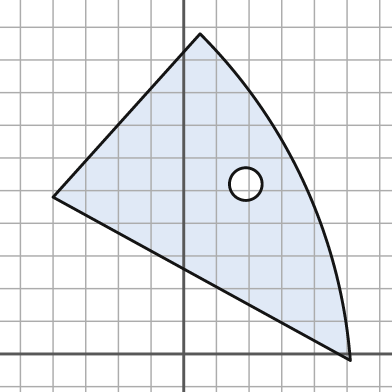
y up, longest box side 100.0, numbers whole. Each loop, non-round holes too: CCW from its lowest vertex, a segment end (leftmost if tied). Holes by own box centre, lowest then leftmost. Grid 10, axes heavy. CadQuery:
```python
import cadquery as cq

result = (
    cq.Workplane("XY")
    .moveTo(51.0, -2.0)
    .threePointArc((37.0, 52.0), (5.0, 98.0))
    .lineTo(-40.0, 48.0)
    .close()
    .moveTo(19.0, 52.0)
    .circle(5.0)
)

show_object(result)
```